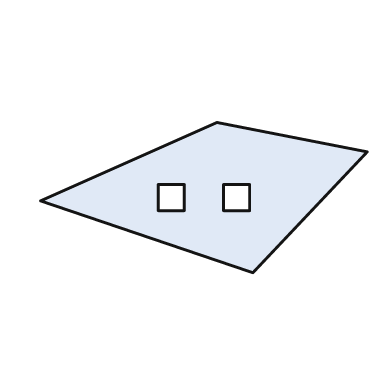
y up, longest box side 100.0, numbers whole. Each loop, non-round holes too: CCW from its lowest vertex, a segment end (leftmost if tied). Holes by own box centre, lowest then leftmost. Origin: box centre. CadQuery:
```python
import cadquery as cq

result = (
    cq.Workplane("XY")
    .moveTo(15.0, -23.0)
    .lineTo(50.0, 14.0)
    .lineTo(4.0, 23.0)
    .lineTo(-50.0, -1.0)
    .close()
    .moveTo(-14.0, -4.0)
    .lineTo(-6.0, -4.0)
    .lineTo(-6.0, 4.0)
    .lineTo(-14.0, 4.0)
    .close()
    .moveTo(6.0, -4.0)
    .lineTo(14.0, -4.0)
    .lineTo(14.0, 4.0)
    .lineTo(6.0, 4.0)
    .close()
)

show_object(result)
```